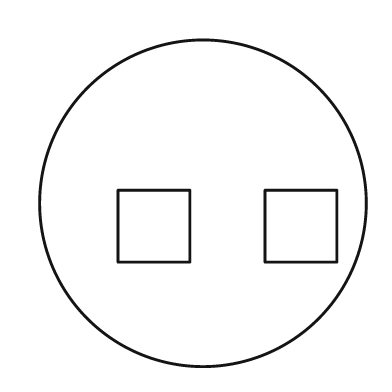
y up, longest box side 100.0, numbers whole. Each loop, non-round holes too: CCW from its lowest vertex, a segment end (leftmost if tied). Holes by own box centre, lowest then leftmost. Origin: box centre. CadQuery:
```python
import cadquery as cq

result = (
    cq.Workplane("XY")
    .moveTo(0.0, 0.0)
    .circle(50.0)
    .moveTo(-26.0, -18.0)
    .lineTo(-4.0, -18.0)
    .lineTo(-4.0, 4.0)
    .lineTo(-26.0, 4.0)
    .close()
    .moveTo(19.0, -18.0)
    .lineTo(41.0, -18.0)
    .lineTo(41.0, 4.0)
    .lineTo(19.0, 4.0)
    .close()
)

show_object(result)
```